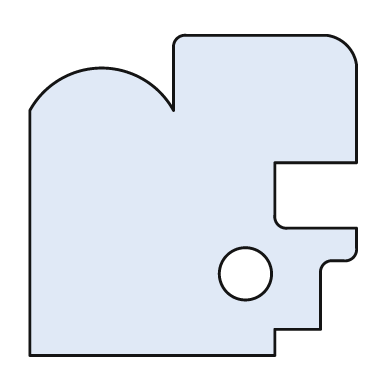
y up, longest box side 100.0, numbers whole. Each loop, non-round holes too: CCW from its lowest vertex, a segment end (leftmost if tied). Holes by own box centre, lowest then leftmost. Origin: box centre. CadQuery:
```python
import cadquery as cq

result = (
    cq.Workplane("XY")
    .moveTo(-50.0, -49.0)
    .lineTo(25.0, -49.0)
    .lineTo(25.0, -41.0)
    .lineTo(39.0, -41.0)
    .lineTo(39.0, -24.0)
    .threePointArc((40.0, -21.0), (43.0, -20.0))
    .lineTo(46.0, -20.0)
    .threePointArc((49.0, -19.0), (50.0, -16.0))
    .lineTo(50.0, -10.0)
    .lineTo(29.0, -10.0)
    .threePointArc((26.0, -9.0), (25.0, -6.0))
    .lineTo(25.0, 10.0)
    .lineTo(50.0, 10.0)
    .lineTo(50.0, 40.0)
    .threePointArc((47.0, 46.0), (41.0, 49.0))
    .lineTo(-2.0, 49.0)
    .threePointArc((-5.0, 48.0), (-6.0, 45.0))
    .lineTo(-6.0, 26.0)
    .threePointArc((-28.0, 39.0), (-50.0, 26.0))
    .close()
    .moveTo(16.0, -24.0)
    .circle(8.0)
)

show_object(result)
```